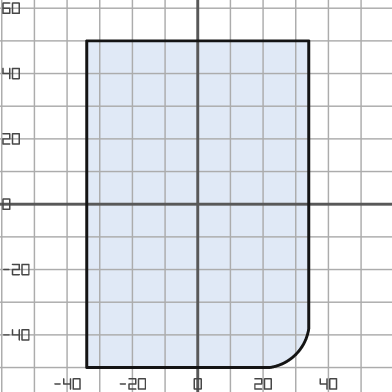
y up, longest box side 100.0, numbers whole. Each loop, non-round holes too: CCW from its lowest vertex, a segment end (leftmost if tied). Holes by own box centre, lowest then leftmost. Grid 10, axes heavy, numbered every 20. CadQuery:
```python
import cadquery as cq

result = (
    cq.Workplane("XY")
    .moveTo(-34.0, -50.0)
    .lineTo(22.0, -50.0)
    .threePointArc((30.0, -46.0), (34.0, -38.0))
    .lineTo(34.0, 50.0)
    .lineTo(-34.0, 50.0)
    .close()
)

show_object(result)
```